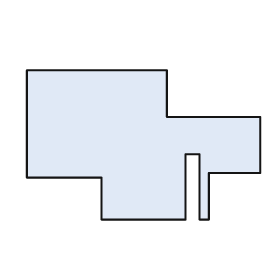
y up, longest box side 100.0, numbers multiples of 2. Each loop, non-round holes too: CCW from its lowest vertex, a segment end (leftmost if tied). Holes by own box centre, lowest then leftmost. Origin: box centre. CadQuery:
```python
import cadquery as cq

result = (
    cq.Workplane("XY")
    .moveTo(-18.0, -32.0)
    .lineTo(18.0, -32.0)
    .lineTo(18.0, -4.0)
    .lineTo(24.0, -4.0)
    .lineTo(24.0, -32.0)
    .lineTo(28.0, -32.0)
    .lineTo(28.0, -12.0)
    .lineTo(50.0, -12.0)
    .lineTo(50.0, 12.0)
    .lineTo(10.0, 12.0)
    .lineTo(10.0, 32.0)
    .lineTo(-50.0, 32.0)
    .lineTo(-50.0, -14.0)
    .lineTo(-18.0, -14.0)
    .close()
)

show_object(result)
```